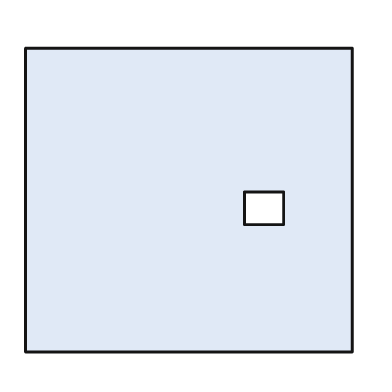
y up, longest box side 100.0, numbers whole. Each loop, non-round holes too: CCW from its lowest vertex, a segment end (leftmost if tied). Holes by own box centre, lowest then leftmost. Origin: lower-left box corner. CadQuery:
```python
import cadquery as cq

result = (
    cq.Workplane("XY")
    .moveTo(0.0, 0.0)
    .lineTo(100.0, 0.0)
    .lineTo(100.0, 93.0)
    .lineTo(0.0, 93.0)
    .close()
    .moveTo(67.0, 39.0)
    .lineTo(79.0, 39.0)
    .lineTo(79.0, 49.0)
    .lineTo(67.0, 49.0)
    .close()
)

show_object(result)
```